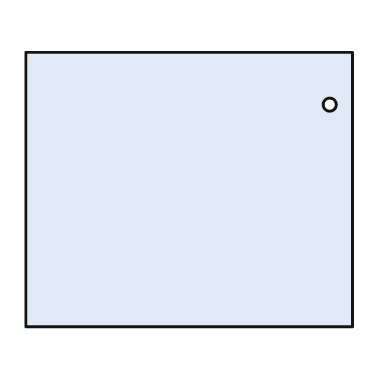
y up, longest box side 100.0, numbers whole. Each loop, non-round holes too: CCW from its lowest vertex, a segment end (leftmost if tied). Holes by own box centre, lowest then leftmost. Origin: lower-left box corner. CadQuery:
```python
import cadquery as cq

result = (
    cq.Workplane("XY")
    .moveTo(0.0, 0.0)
    .lineTo(100.0, 0.0)
    .lineTo(100.0, 84.0)
    .lineTo(0.0, 84.0)
    .close()
    .moveTo(93.0, 68.0)
    .circle(2.0)
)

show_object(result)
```